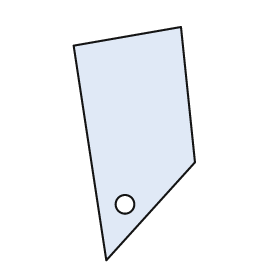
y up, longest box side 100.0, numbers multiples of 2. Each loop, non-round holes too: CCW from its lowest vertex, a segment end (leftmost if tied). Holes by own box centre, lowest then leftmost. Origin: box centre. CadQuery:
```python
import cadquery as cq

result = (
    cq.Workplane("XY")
    .moveTo(-12.0, -50.0)
    .lineTo(26.0, -8.0)
    .lineTo(20.0, 50.0)
    .lineTo(-26.0, 42.0)
    .close()
    .moveTo(-4.0, -26.0)
    .circle(4.0)
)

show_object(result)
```